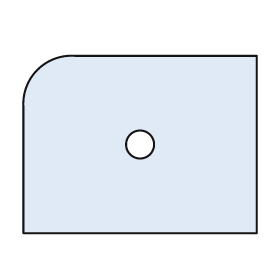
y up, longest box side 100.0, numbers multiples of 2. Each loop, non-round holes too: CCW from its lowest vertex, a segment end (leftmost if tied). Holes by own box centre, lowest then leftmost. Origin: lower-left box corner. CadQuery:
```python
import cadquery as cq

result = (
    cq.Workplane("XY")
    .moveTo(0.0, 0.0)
    .lineTo(100.0, 0.0)
    .lineTo(100.0, 76.0)
    .lineTo(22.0, 76.0)
    .threePointArc((6.0, 70.0), (0.0, 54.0))
    .close()
    .moveTo(50.0, 38.0)
    .circle(6.0)
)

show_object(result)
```